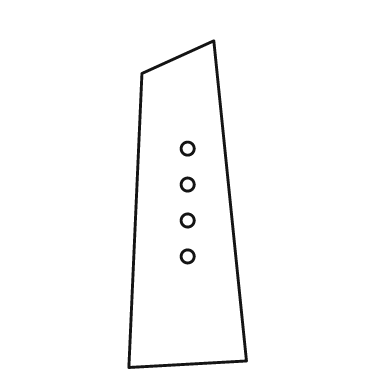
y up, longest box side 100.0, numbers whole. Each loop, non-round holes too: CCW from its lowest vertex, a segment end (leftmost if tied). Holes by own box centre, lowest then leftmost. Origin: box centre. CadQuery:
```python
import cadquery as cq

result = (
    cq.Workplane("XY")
    .moveTo(-18.0, -50.0)
    .lineTo(18.0, -48.0)
    .lineTo(8.0, 50.0)
    .lineTo(-14.0, 40.0)
    .close()
    .moveTo(0.0, -16.0)
    .circle(2.0)
    .moveTo(0.0, -5.0)
    .circle(2.0)
    .moveTo(0.0, 6.0)
    .circle(2.0)
    .moveTo(0.0, 17.0)
    .circle(2.0)
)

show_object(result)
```